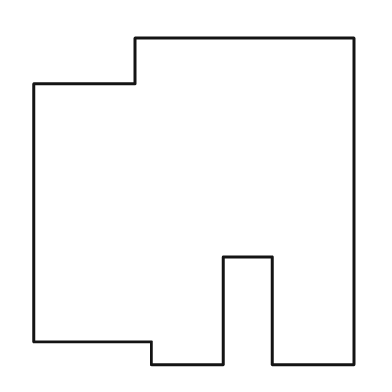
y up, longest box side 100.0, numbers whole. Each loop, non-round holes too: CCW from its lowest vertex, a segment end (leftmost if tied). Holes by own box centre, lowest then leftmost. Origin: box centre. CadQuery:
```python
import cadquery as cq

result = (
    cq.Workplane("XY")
    .moveTo(-13.0, -50.0)
    .lineTo(9.0, -50.0)
    .lineTo(9.0, -17.0)
    .lineTo(24.0, -17.0)
    .lineTo(24.0, -50.0)
    .lineTo(49.0, -50.0)
    .lineTo(49.0, 50.0)
    .lineTo(-18.0, 50.0)
    .lineTo(-18.0, 36.0)
    .lineTo(-49.0, 36.0)
    .lineTo(-49.0, -43.0)
    .lineTo(-13.0, -43.0)
    .close()
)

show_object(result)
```